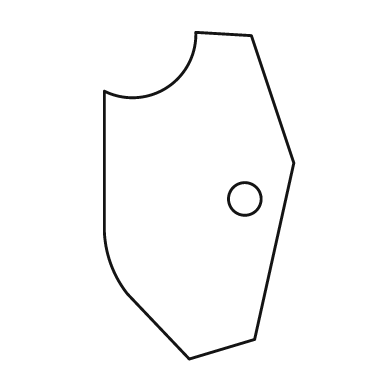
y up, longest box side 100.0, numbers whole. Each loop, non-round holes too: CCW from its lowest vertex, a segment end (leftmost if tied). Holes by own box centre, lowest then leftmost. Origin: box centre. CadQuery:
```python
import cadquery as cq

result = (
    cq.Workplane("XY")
    .moveTo(-3.0, -50.0)
    .lineTo(17.0, -44.0)
    .lineTo(29.0, 10.0)
    .lineTo(16.0, 49.0)
    .lineTo(-1.0, 50.0)
    .threePointArc((-10.0, 33.0), (-29.0, 32.0))
    .lineTo(-29.0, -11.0)
    .threePointArc((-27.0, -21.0), (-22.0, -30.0))
    .close()
    .moveTo(14.0, -1.0)
    .circle(5.0)
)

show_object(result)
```